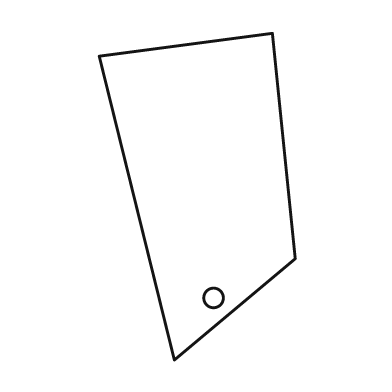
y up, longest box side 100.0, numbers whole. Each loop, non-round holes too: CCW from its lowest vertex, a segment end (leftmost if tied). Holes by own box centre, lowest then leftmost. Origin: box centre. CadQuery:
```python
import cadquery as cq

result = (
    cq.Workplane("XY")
    .moveTo(-7.0, -50.0)
    .lineTo(30.0, -19.0)
    .lineTo(23.0, 50.0)
    .lineTo(-30.0, 43.0)
    .close()
    .moveTo(5.0, -31.0)
    .circle(3.0)
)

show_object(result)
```